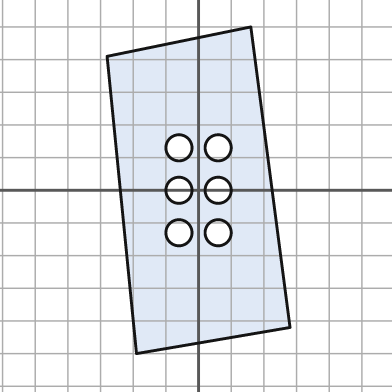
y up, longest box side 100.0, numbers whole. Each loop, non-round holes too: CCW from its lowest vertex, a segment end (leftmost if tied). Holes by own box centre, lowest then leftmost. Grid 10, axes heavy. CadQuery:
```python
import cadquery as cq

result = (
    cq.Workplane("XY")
    .moveTo(-19.0, -50.0)
    .lineTo(28.0, -42.0)
    .lineTo(16.0, 50.0)
    .lineTo(-28.0, 41.0)
    .close()
    .moveTo(-6.0, -13.0)
    .circle(4.0)
    .moveTo(6.0, -13.0)
    .circle(4.0)
    .moveTo(-6.0, 0.0)
    .circle(4.0)
    .moveTo(6.0, 0.0)
    .circle(4.0)
    .moveTo(-6.0, 13.0)
    .circle(4.0)
    .moveTo(6.0, 13.0)
    .circle(4.0)
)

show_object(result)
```